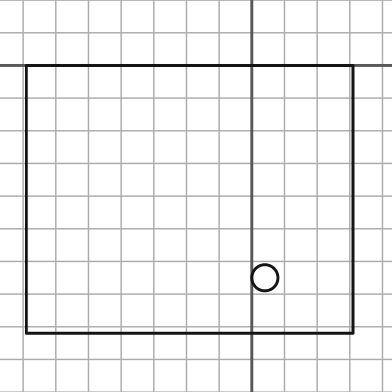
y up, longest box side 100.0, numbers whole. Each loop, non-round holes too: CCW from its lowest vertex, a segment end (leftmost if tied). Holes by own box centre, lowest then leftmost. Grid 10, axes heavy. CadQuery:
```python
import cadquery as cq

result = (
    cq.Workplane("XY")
    .moveTo(-69.0, -82.0)
    .lineTo(31.0, -82.0)
    .lineTo(31.0, 0.0)
    .lineTo(-69.0, 0.0)
    .close()
    .moveTo(4.0, -65.0)
    .circle(4.0)
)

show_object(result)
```